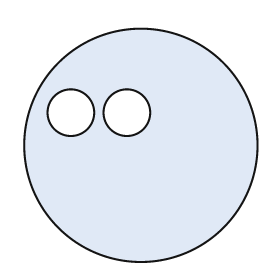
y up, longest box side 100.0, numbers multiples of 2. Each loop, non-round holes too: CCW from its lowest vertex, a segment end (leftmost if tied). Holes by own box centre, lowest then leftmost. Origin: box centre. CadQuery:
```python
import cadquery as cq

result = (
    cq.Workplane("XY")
    .moveTo(0.0, 0.0)
    .circle(50.0)
    .moveTo(-30.0, 14.0)
    .circle(10.0)
    .moveTo(-6.0, 14.0)
    .circle(10.0)
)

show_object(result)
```